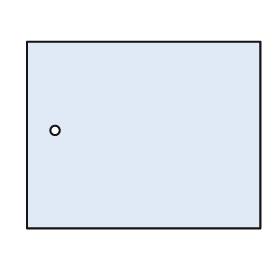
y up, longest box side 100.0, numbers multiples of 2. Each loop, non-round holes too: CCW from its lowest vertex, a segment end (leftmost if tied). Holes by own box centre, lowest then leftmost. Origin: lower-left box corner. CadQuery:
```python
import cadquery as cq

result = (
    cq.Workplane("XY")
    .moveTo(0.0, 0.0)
    .lineTo(100.0, 0.0)
    .lineTo(100.0, 80.0)
    .lineTo(0.0, 80.0)
    .close()
    .moveTo(12.0, 42.0)
    .circle(2.0)
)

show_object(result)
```